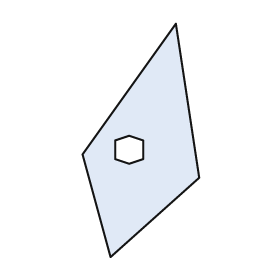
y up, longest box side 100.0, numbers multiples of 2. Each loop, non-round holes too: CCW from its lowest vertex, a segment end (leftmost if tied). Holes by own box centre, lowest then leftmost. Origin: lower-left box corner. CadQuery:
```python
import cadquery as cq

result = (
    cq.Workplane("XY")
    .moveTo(12.0, 0.0)
    .lineTo(50.0, 34.0)
    .lineTo(40.0, 100.0)
    .lineTo(0.0, 44.0)
    .close()
    .moveTo(20.0, 40.0)
    .lineTo(26.0, 42.0)
    .lineTo(26.0, 50.0)
    .lineTo(20.0, 52.0)
    .lineTo(14.0, 50.0)
    .lineTo(14.0, 42.0)
    .close()
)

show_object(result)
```